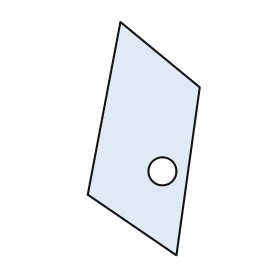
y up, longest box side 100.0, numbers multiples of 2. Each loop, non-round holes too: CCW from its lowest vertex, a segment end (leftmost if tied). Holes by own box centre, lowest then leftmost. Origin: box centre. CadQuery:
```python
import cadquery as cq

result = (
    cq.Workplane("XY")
    .moveTo(14.0, -50.0)
    .lineTo(24.0, 22.0)
    .lineTo(-10.0, 50.0)
    .lineTo(-24.0, -24.0)
    .close()
    .moveTo(8.0, -14.0)
    .circle(6.0)
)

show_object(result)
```